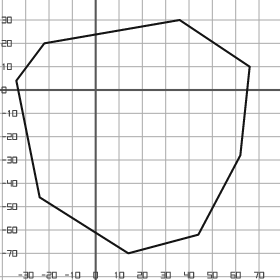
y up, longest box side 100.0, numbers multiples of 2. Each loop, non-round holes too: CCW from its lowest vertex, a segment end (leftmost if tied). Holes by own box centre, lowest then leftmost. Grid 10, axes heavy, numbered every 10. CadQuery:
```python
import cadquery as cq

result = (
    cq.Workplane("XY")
    .moveTo(14.0, -70.0)
    .lineTo(44.0, -62.0)
    .lineTo(62.0, -28.0)
    .lineTo(66.0, 10.0)
    .lineTo(36.0, 30.0)
    .lineTo(-22.0, 20.0)
    .lineTo(-34.0, 4.0)
    .lineTo(-24.0, -46.0)
    .close()
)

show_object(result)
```